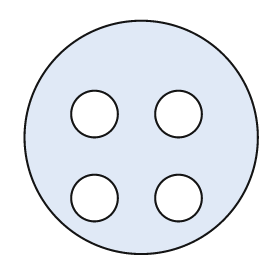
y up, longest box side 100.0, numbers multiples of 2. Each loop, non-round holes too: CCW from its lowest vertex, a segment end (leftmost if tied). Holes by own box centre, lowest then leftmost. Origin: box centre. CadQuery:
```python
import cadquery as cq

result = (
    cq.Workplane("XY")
    .moveTo(0.0, 0.0)
    .circle(50.0)
    .moveTo(-20.0, -26.0)
    .circle(10.0)
    .moveTo(16.0, -26.0)
    .circle(10.0)
    .moveTo(-20.0, 10.0)
    .circle(10.0)
    .moveTo(16.0, 10.0)
    .circle(10.0)
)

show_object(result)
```